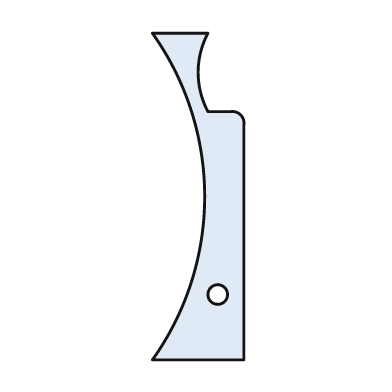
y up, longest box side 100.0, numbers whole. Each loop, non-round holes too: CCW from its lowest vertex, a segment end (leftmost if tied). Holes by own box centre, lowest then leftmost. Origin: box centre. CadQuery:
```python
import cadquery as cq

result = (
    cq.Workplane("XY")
    .moveTo(-14.0, -50.0)
    .lineTo(14.0, -50.0)
    .lineTo(14.0, 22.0)
    .threePointArc((13.0, 25.0), (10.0, 26.0))
    .lineTo(3.0, 26.0)
    .threePointArc((0.0, 38.0), (3.0, 50.0))
    .lineTo(-14.0, 50.0)
    .threePointArc((2.0, 0.0), (-14.0, -50.0))
    .close()
    .moveTo(6.0, -30.0)
    .circle(3.0)
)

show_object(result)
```